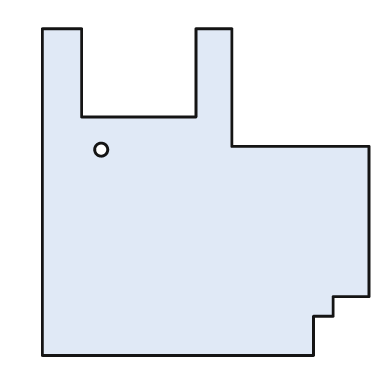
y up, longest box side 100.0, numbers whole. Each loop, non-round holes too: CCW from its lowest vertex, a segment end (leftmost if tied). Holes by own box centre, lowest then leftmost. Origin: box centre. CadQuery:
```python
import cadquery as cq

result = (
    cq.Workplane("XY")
    .moveTo(-50.0, -50.0)
    .lineTo(33.0, -50.0)
    .lineTo(33.0, -38.0)
    .lineTo(39.0, -38.0)
    .lineTo(39.0, -32.0)
    .lineTo(50.0, -32.0)
    .lineTo(50.0, 14.0)
    .lineTo(8.0, 14.0)
    .lineTo(8.0, 50.0)
    .lineTo(-3.0, 50.0)
    .lineTo(-3.0, 23.0)
    .lineTo(-38.0, 23.0)
    .lineTo(-38.0, 50.0)
    .lineTo(-50.0, 50.0)
    .close()
    .moveTo(-32.0, 13.0)
    .circle(2.0)
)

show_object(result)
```